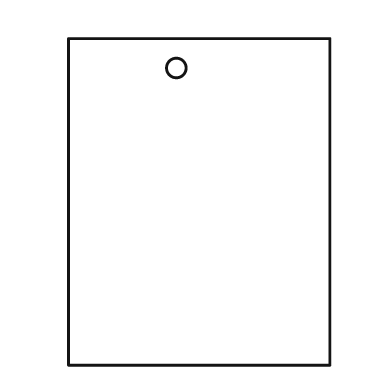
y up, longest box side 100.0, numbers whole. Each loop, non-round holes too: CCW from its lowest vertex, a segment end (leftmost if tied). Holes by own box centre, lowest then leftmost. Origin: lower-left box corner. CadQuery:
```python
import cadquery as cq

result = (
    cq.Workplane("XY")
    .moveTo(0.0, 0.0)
    .lineTo(80.0, 0.0)
    .lineTo(80.0, 100.0)
    .lineTo(0.0, 100.0)
    .close()
    .moveTo(33.0, 91.0)
    .circle(3.0)
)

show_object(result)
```